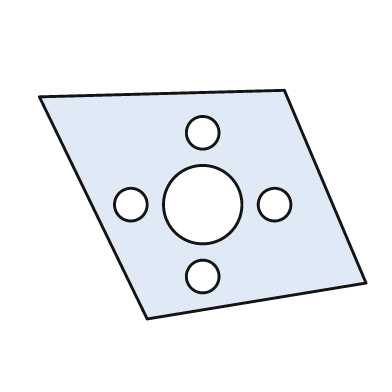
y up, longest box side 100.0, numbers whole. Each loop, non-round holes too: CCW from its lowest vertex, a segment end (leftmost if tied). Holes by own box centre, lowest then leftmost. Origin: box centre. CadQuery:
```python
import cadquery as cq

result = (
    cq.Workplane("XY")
    .moveTo(-17.0, -35.0)
    .lineTo(50.0, -24.0)
    .lineTo(25.0, 35.0)
    .lineTo(-50.0, 33.0)
    .close()
    .moveTo(0.0, -22.0)
    .circle(5.0)
    .moveTo(-22.0, 0.0)
    .circle(5.0)
    .moveTo(0.0, 0.0)
    .circle(12.0)
    .moveTo(22.0, 0.0)
    .circle(5.0)
    .moveTo(0.0, 22.0)
    .circle(5.0)
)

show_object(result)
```